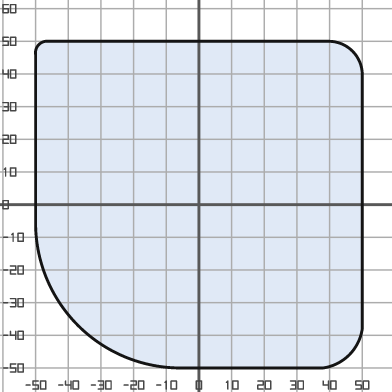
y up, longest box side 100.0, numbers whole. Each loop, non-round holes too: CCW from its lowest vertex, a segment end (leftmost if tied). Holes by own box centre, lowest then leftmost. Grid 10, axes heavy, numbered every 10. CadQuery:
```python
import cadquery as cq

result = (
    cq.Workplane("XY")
    .moveTo(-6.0, -50.0)
    .lineTo(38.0, -50.0)
    .threePointArc((46.0, -46.0), (50.0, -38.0))
    .lineTo(50.0, 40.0)
    .threePointArc((47.0, 47.0), (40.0, 50.0))
    .lineTo(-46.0, 50.0)
    .threePointArc((-49.0, 49.0), (-50.0, 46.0))
    .lineTo(-50.0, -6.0)
    .threePointArc((-37.0, -37.0), (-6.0, -50.0))
    .close()
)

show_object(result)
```